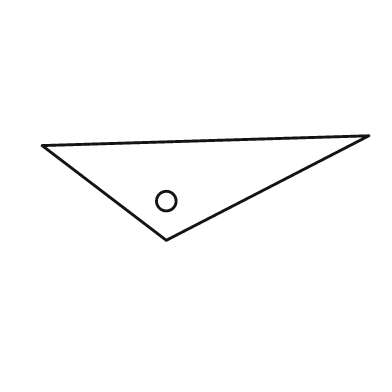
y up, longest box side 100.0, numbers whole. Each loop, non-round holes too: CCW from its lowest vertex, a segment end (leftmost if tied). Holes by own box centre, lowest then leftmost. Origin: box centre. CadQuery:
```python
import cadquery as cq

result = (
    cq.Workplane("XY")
    .moveTo(-12.0, -16.0)
    .lineTo(50.0, 16.0)
    .lineTo(-50.0, 13.0)
    .close()
    .moveTo(-12.0, -4.0)
    .circle(3.0)
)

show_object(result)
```